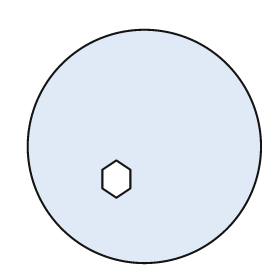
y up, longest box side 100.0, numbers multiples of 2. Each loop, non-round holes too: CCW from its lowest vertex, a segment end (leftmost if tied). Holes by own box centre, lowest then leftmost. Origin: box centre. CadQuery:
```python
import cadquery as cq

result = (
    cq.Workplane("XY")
    .moveTo(0.0, 0.0)
    .circle(50.0)
    .moveTo(-12.0, -22.0)
    .lineTo(-6.0, -18.0)
    .lineTo(-6.0, -10.0)
    .lineTo(-12.0, -6.0)
    .lineTo(-18.0, -10.0)
    .lineTo(-18.0, -18.0)
    .close()
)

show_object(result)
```